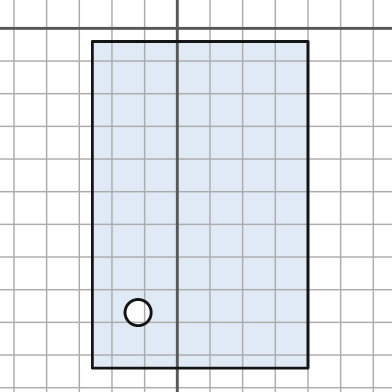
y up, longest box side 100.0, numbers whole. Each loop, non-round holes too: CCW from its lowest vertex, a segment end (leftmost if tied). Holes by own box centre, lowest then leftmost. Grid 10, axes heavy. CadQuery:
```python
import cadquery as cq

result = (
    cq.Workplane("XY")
    .moveTo(-26.0, -104.0)
    .lineTo(40.0, -104.0)
    .lineTo(40.0, -4.0)
    .lineTo(-26.0, -4.0)
    .close()
    .moveTo(-12.0, -87.0)
    .circle(4.0)
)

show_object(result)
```